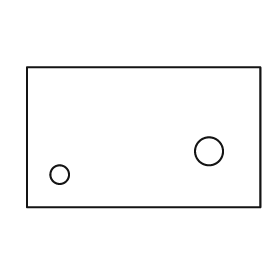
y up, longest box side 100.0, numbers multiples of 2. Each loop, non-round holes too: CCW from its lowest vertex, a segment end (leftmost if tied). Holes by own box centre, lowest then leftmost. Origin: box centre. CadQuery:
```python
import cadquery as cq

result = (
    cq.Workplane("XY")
    .moveTo(-50.0, -30.0)
    .lineTo(50.0, -30.0)
    .lineTo(50.0, 30.0)
    .lineTo(-50.0, 30.0)
    .close()
    .moveTo(-36.0, -16.0)
    .circle(4.0)
    .moveTo(28.0, -6.0)
    .circle(6.0)
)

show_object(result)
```